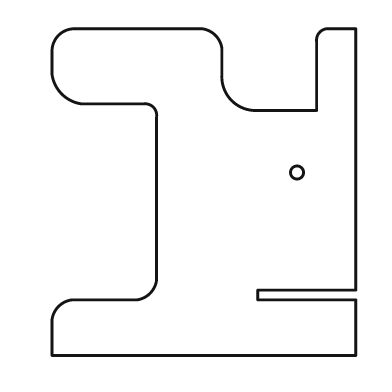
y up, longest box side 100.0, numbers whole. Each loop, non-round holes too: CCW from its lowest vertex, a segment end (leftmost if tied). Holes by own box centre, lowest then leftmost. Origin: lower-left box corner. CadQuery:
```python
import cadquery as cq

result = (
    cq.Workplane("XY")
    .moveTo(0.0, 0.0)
    .lineTo(93.0, 0.0)
    .lineTo(93.0, 17.0)
    .lineTo(63.0, 17.0)
    .lineTo(63.0, 20.0)
    .lineTo(93.0, 20.0)
    .lineTo(93.0, 100.0)
    .lineTo(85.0, 100.0)
    .threePointArc((82.0, 99.0), (81.0, 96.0))
    .lineTo(81.0, 75.0)
    .lineTo(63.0, 75.0)
    .threePointArc((55.0, 78.0), (52.0, 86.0))
    .lineTo(52.0, 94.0)
    .threePointArc((50.0, 98.0), (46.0, 100.0))
    .lineTo(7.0, 100.0)
    .threePointArc((2.0, 98.0), (0.0, 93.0))
    .lineTo(0.0, 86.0)
    .threePointArc((3.0, 80.0), (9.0, 77.0))
    .lineTo(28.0, 77.0)
    .threePointArc((31.0, 76.0), (32.0, 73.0))
    .lineTo(32.0, 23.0)
    .threePointArc((30.0, 19.0), (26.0, 17.0))
    .lineTo(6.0, 17.0)
    .threePointArc((2.0, 15.0), (0.0, 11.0))
    .close()
    .moveTo(75.0, 56.0)
    .circle(2.0)
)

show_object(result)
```